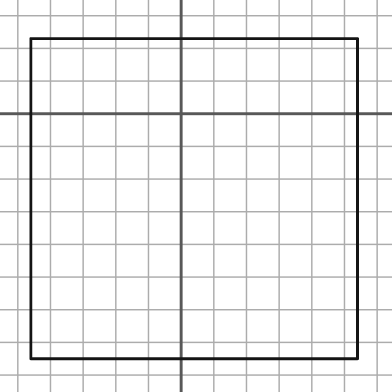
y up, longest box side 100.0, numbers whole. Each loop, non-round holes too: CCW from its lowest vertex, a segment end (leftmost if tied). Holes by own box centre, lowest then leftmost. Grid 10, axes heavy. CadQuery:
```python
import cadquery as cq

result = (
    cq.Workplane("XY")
    .moveTo(-46.0, -75.0)
    .lineTo(54.0, -75.0)
    .lineTo(54.0, 23.0)
    .lineTo(-46.0, 23.0)
    .close()
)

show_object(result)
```